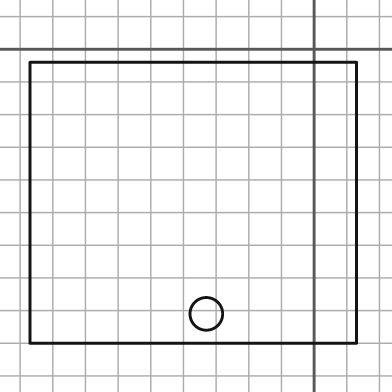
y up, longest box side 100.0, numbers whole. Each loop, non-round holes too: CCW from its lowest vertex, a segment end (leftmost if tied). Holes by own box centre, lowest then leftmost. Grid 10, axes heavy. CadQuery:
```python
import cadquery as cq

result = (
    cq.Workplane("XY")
    .moveTo(-87.0, -90.0)
    .lineTo(13.0, -90.0)
    .lineTo(13.0, -4.0)
    .lineTo(-87.0, -4.0)
    .close()
    .moveTo(-33.0, -81.0)
    .circle(5.0)
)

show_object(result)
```